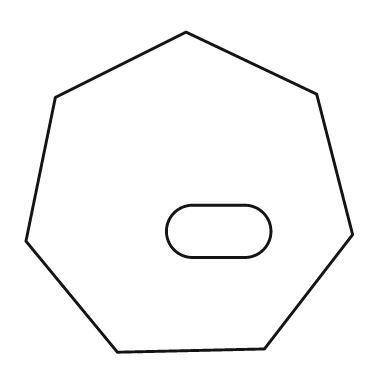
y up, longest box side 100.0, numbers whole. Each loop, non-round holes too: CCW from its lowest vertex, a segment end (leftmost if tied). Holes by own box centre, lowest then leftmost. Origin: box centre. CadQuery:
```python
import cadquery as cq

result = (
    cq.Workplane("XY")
    .moveTo(-22.0, -49.0)
    .lineTo(23.0, -48.0)
    .lineTo(50.0, -13.0)
    .lineTo(39.0, 30.0)
    .lineTo(-1.0, 49.0)
    .lineTo(-41.0, 29.0)
    .lineTo(-50.0, -15.0)
    .close()
    .moveTo(1.0, -20.0)
    .lineTo(17.0, -20.0)
    .threePointArc((25.0, -12.0), (17.0, -4.0))
    .lineTo(1.0, -4.0)
    .threePointArc((-7.0, -12.0), (1.0, -20.0))
    .close()
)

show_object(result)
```